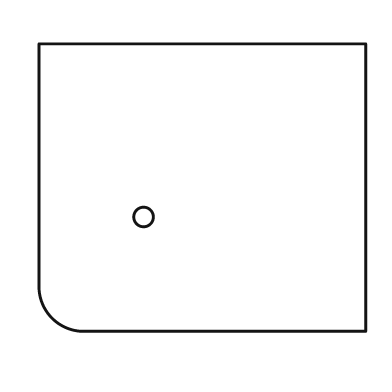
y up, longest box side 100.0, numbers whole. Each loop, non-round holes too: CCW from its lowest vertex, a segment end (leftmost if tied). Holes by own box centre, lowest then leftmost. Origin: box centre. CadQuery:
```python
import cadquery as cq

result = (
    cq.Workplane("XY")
    .moveTo(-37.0, -44.0)
    .lineTo(50.0, -44.0)
    .lineTo(50.0, 44.0)
    .lineTo(-50.0, 44.0)
    .lineTo(-50.0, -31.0)
    .threePointArc((-46.0, -40.0), (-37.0, -44.0))
    .close()
    .moveTo(-18.0, -9.0)
    .circle(3.0)
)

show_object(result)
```